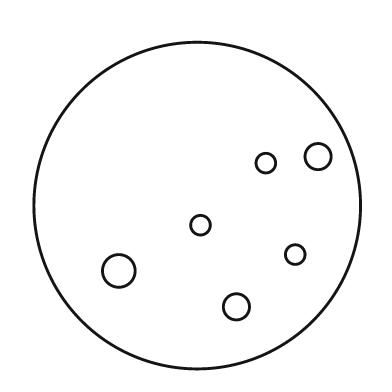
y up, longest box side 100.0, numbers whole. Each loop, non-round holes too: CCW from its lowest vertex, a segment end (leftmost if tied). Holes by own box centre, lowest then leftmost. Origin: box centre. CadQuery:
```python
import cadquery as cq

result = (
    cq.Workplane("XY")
    .moveTo(0.0, 0.0)
    .circle(50.0)
    .moveTo(12.0, -31.0)
    .circle(4.0)
    .moveTo(-24.0, -20.0)
    .circle(5.0)
    .moveTo(30.0, -15.0)
    .circle(3.0)
    .moveTo(1.0, -6.0)
    .circle(3.0)
    .moveTo(21.0, 13.0)
    .circle(3.0)
    .moveTo(37.0, 15.0)
    .circle(4.0)
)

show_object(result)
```